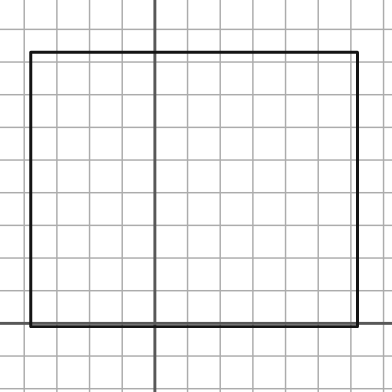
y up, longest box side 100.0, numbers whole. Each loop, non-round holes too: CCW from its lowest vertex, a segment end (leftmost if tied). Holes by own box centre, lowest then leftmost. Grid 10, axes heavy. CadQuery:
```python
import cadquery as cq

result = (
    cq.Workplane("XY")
    .moveTo(-38.0, -1.0)
    .lineTo(62.0, -1.0)
    .lineTo(62.0, 83.0)
    .lineTo(-38.0, 83.0)
    .close()
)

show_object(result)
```